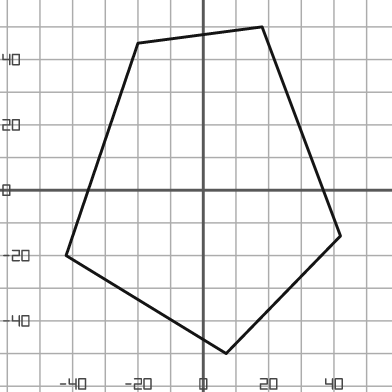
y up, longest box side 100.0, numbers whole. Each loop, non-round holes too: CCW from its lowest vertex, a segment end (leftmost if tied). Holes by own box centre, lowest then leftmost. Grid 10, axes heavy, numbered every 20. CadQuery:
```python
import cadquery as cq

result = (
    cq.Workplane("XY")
    .moveTo(7.0, -50.0)
    .lineTo(42.0, -14.0)
    .lineTo(18.0, 50.0)
    .lineTo(-20.0, 45.0)
    .lineTo(-42.0, -20.0)
    .close()
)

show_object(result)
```